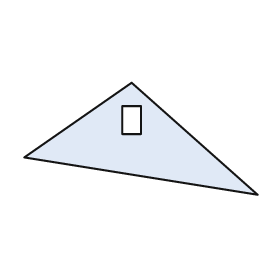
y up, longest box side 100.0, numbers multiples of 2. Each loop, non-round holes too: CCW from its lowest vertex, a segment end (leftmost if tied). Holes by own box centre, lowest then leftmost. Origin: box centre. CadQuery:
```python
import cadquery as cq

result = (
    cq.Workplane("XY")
    .moveTo(50.0, -24.0)
    .lineTo(-4.0, 24.0)
    .lineTo(-50.0, -8.0)
    .close()
    .moveTo(-8.0, 2.0)
    .lineTo(0.0, 2.0)
    .lineTo(0.0, 14.0)
    .lineTo(-8.0, 14.0)
    .close()
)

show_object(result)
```